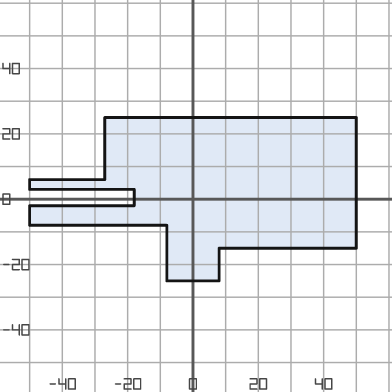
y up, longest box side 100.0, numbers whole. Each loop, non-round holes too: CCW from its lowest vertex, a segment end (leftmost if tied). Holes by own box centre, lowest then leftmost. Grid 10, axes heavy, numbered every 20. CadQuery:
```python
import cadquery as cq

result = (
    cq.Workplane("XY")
    .moveTo(-8.0, -25.0)
    .lineTo(8.0, -25.0)
    .lineTo(8.0, -15.0)
    .lineTo(50.0, -15.0)
    .lineTo(50.0, 25.0)
    .lineTo(-27.0, 25.0)
    .lineTo(-27.0, 6.0)
    .lineTo(-50.0, 6.0)
    .lineTo(-50.0, 3.0)
    .lineTo(-18.0, 3.0)
    .lineTo(-18.0, -2.0)
    .lineTo(-50.0, -2.0)
    .lineTo(-50.0, -8.0)
    .lineTo(-8.0, -8.0)
    .close()
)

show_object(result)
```